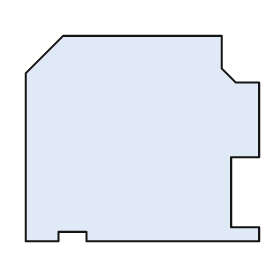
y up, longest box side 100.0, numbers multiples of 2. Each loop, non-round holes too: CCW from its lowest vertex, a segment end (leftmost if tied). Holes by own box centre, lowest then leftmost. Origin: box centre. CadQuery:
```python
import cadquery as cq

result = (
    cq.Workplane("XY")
    .moveTo(-50.0, -44.0)
    .lineTo(-36.0, -44.0)
    .lineTo(-36.0, -40.0)
    .lineTo(-24.0, -40.0)
    .lineTo(-24.0, -44.0)
    .lineTo(50.0, -44.0)
    .lineTo(50.0, -38.0)
    .lineTo(38.0, -38.0)
    .lineTo(38.0, -8.0)
    .lineTo(50.0, -8.0)
    .lineTo(50.0, 24.0)
    .lineTo(40.0, 24.0)
    .lineTo(34.0, 30.0)
    .lineTo(34.0, 44.0)
    .lineTo(-34.0, 44.0)
    .lineTo(-50.0, 28.0)
    .close()
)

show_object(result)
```